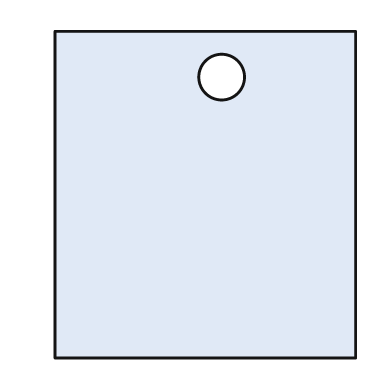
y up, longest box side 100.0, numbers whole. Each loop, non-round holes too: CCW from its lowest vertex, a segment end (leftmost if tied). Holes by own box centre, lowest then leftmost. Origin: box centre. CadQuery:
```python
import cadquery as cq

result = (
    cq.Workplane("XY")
    .moveTo(-46.0, -50.0)
    .lineTo(46.0, -50.0)
    .lineTo(46.0, 50.0)
    .lineTo(-46.0, 50.0)
    .close()
    .moveTo(5.0, 36.0)
    .circle(7.0)
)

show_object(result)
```